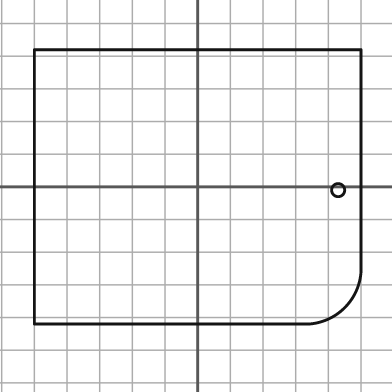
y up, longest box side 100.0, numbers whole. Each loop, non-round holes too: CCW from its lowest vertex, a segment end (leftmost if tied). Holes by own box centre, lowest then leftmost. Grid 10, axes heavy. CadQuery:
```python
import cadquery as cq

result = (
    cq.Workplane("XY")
    .moveTo(-50.0, -42.0)
    .lineTo(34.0, -42.0)
    .threePointArc((45.0, -37.0), (50.0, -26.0))
    .lineTo(50.0, 42.0)
    .lineTo(-50.0, 42.0)
    .close()
    .moveTo(43.0, -1.0)
    .circle(2.0)
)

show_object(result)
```